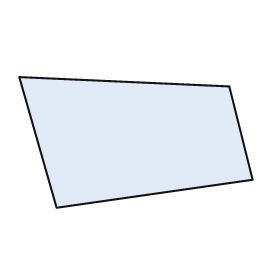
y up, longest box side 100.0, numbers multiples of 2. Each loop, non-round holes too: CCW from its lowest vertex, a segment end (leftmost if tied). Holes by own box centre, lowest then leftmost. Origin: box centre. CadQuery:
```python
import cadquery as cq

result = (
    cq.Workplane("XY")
    .moveTo(-34.0, -28.0)
    .lineTo(50.0, -16.0)
    .lineTo(40.0, 24.0)
    .lineTo(-50.0, 28.0)
    .close()
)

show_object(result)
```